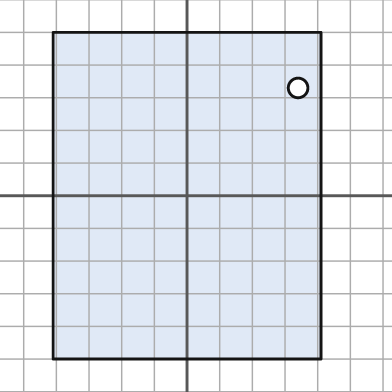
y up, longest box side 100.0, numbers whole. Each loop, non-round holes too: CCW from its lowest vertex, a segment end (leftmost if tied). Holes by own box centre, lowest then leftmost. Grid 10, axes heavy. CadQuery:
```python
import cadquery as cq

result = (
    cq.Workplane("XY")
    .moveTo(-41.0, -50.0)
    .lineTo(41.0, -50.0)
    .lineTo(41.0, 50.0)
    .lineTo(-41.0, 50.0)
    .close()
    .moveTo(34.0, 33.0)
    .circle(3.0)
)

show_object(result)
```